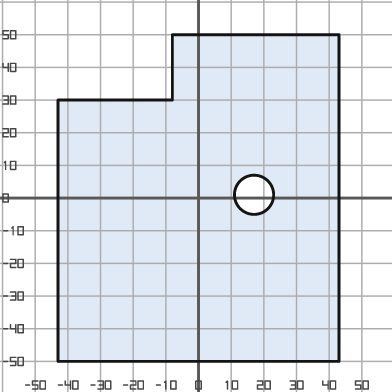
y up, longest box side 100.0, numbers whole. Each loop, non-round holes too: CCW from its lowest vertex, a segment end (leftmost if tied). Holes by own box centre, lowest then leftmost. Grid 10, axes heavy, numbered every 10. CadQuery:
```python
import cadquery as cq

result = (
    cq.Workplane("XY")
    .moveTo(-43.0, -50.0)
    .lineTo(43.0, -50.0)
    .lineTo(43.0, 50.0)
    .lineTo(-8.0, 50.0)
    .lineTo(-8.0, 30.0)
    .lineTo(-43.0, 30.0)
    .close()
    .moveTo(17.0, 1.0)
    .circle(6.0)
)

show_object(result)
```